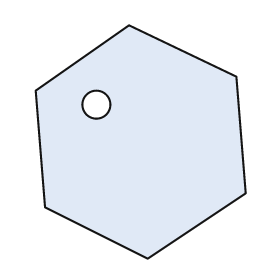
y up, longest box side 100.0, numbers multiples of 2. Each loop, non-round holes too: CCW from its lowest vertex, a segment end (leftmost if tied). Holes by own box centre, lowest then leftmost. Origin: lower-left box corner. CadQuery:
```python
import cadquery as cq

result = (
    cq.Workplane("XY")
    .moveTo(48.0, 0.0)
    .lineTo(90.0, 28.0)
    .lineTo(86.0, 78.0)
    .lineTo(40.0, 100.0)
    .lineTo(0.0, 72.0)
    .lineTo(4.0, 22.0)
    .close()
    .moveTo(26.0, 66.0)
    .circle(6.0)
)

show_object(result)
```